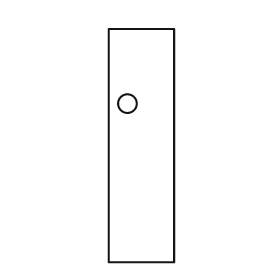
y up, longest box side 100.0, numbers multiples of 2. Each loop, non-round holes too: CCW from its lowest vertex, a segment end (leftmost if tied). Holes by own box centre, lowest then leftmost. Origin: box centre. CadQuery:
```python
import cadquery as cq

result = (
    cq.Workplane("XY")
    .moveTo(-14.0, -50.0)
    .lineTo(14.0, -50.0)
    .lineTo(14.0, 50.0)
    .lineTo(-14.0, 50.0)
    .close()
    .moveTo(-6.0, 18.0)
    .circle(4.0)
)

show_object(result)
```